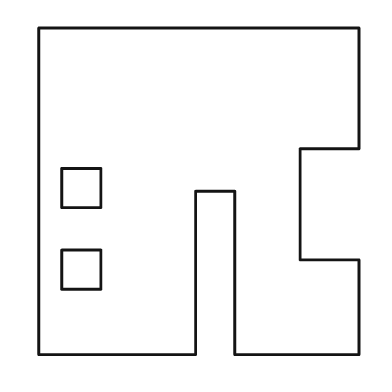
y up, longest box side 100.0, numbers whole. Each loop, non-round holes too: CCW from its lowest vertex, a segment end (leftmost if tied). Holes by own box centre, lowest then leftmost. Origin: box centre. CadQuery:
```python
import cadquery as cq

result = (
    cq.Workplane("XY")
    .moveTo(-49.0, -50.0)
    .lineTo(-1.0, -50.0)
    .lineTo(-1.0, 0.0)
    .lineTo(11.0, 0.0)
    .lineTo(11.0, -50.0)
    .lineTo(49.0, -50.0)
    .lineTo(49.0, -21.0)
    .lineTo(31.0, -21.0)
    .lineTo(31.0, 13.0)
    .lineTo(49.0, 13.0)
    .lineTo(49.0, 50.0)
    .lineTo(-49.0, 50.0)
    .close()
    .moveTo(-42.0, -30.0)
    .lineTo(-30.0, -30.0)
    .lineTo(-30.0, -18.0)
    .lineTo(-42.0, -18.0)
    .close()
    .moveTo(-42.0, -5.0)
    .lineTo(-30.0, -5.0)
    .lineTo(-30.0, 7.0)
    .lineTo(-42.0, 7.0)
    .close()
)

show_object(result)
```